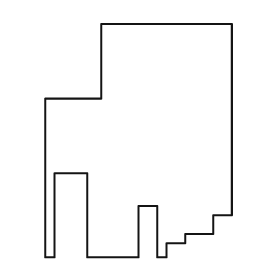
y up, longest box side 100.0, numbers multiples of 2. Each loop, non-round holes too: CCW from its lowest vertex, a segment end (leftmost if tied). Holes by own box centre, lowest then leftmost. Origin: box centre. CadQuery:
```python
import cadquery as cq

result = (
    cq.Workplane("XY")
    .moveTo(-40.0, -50.0)
    .lineTo(-36.0, -50.0)
    .lineTo(-36.0, -14.0)
    .lineTo(-22.0, -14.0)
    .lineTo(-22.0, -50.0)
    .lineTo(0.0, -50.0)
    .lineTo(0.0, -28.0)
    .lineTo(8.0, -28.0)
    .lineTo(8.0, -50.0)
    .lineTo(12.0, -50.0)
    .lineTo(12.0, -44.0)
    .lineTo(20.0, -44.0)
    .lineTo(20.0, -40.0)
    .lineTo(32.0, -40.0)
    .lineTo(32.0, -32.0)
    .lineTo(40.0, -32.0)
    .lineTo(40.0, 50.0)
    .lineTo(-16.0, 50.0)
    .lineTo(-16.0, 18.0)
    .lineTo(-40.0, 18.0)
    .close()
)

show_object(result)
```